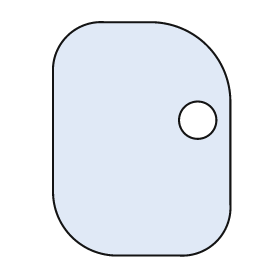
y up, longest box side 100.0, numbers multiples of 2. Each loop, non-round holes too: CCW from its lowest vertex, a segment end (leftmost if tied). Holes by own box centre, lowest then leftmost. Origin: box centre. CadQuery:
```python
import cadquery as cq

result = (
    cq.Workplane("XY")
    .moveTo(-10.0, -50.0)
    .lineTo(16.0, -50.0)
    .threePointArc((32.0, -44.0), (38.0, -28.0))
    .lineTo(38.0, 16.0)
    .threePointArc((28.0, 40.0), (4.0, 50.0))
    .lineTo(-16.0, 50.0)
    .threePointArc((-32.0, 44.0), (-38.0, 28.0))
    .lineTo(-38.0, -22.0)
    .threePointArc((-30.0, -42.0), (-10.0, -50.0))
    .close()
    .moveTo(24.0, 8.0)
    .circle(8.0)
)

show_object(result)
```